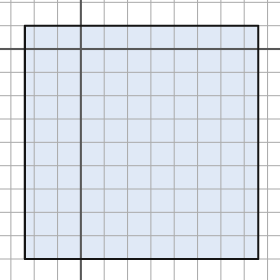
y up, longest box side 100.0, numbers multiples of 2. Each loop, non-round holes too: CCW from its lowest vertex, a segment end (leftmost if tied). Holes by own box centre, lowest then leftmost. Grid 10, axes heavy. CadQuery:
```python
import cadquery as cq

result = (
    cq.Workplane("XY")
    .moveTo(-24.0, -90.0)
    .lineTo(76.0, -90.0)
    .lineTo(76.0, 10.0)
    .lineTo(-24.0, 10.0)
    .close()
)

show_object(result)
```